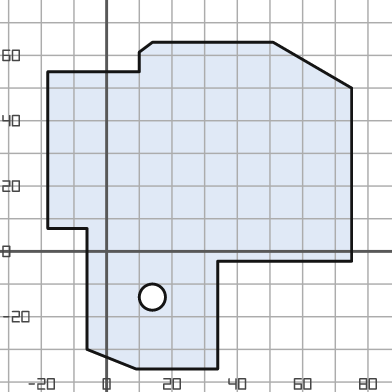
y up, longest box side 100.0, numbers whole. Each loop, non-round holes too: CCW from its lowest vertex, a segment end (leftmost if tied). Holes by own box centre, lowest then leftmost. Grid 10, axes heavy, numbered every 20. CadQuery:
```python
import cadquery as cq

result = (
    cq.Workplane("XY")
    .moveTo(9.0, -36.0)
    .lineTo(34.0, -36.0)
    .lineTo(34.0, -3.0)
    .lineTo(75.0, -3.0)
    .lineTo(75.0, 50.0)
    .lineTo(51.0, 64.0)
    .lineTo(14.0, 64.0)
    .lineTo(10.0, 61.0)
    .lineTo(10.0, 55.0)
    .lineTo(-18.0, 55.0)
    .lineTo(-18.0, 7.0)
    .lineTo(-6.0, 7.0)
    .lineTo(-6.0, -30.0)
    .close()
    .moveTo(14.0, -14.0)
    .circle(4.0)
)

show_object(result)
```